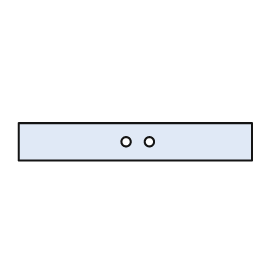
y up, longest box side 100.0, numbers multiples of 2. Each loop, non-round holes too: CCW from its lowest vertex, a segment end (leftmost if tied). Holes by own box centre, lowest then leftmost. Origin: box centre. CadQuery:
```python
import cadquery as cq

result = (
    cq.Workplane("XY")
    .moveTo(-50.0, -8.0)
    .lineTo(50.0, -8.0)
    .lineTo(50.0, 8.0)
    .lineTo(-50.0, 8.0)
    .close()
    .moveTo(-4.0, 0.0)
    .circle(2.0)
    .moveTo(6.0, 0.0)
    .circle(2.0)
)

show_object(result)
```